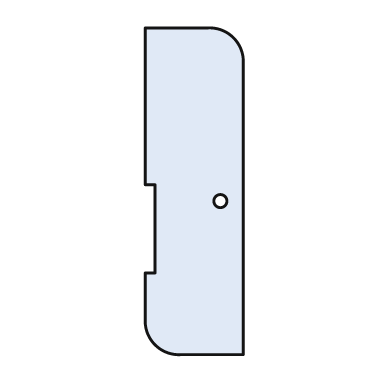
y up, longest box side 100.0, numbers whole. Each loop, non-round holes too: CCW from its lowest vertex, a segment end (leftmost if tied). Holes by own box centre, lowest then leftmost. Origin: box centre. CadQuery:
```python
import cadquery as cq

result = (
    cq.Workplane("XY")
    .moveTo(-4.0, -50.0)
    .lineTo(15.0, -50.0)
    .lineTo(15.0, 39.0)
    .threePointArc((12.0, 47.0), (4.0, 50.0))
    .lineTo(-15.0, 50.0)
    .lineTo(-15.0, 2.0)
    .lineTo(-12.0, 2.0)
    .lineTo(-12.0, -25.0)
    .lineTo(-15.0, -25.0)
    .lineTo(-15.0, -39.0)
    .threePointArc((-12.0, -47.0), (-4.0, -50.0))
    .close()
    .moveTo(8.0, -3.0)
    .circle(2.0)
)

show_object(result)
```